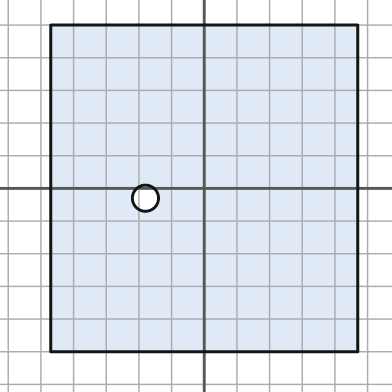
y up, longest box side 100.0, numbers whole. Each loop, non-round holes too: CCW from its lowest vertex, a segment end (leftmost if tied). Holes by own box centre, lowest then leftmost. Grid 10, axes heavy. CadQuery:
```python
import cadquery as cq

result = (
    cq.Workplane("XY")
    .moveTo(-47.0, -50.0)
    .lineTo(47.0, -50.0)
    .lineTo(47.0, 50.0)
    .lineTo(-47.0, 50.0)
    .close()
    .moveTo(-18.0, -3.0)
    .circle(4.0)
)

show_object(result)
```